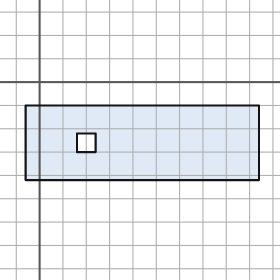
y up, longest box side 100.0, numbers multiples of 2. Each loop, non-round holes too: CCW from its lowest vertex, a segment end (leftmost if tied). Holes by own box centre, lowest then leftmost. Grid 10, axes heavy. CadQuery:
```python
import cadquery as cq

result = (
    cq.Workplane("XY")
    .moveTo(-6.0, -42.0)
    .lineTo(94.0, -42.0)
    .lineTo(94.0, -10.0)
    .lineTo(-6.0, -10.0)
    .close()
    .moveTo(16.0, -30.0)
    .lineTo(24.0, -30.0)
    .lineTo(24.0, -22.0)
    .lineTo(16.0, -22.0)
    .close()
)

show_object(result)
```